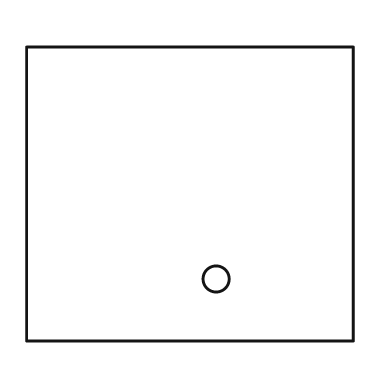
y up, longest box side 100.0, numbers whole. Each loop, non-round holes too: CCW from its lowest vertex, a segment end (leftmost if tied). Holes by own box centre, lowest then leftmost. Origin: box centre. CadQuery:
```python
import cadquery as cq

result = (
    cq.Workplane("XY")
    .moveTo(-50.0, -45.0)
    .lineTo(50.0, -45.0)
    .lineTo(50.0, 45.0)
    .lineTo(-50.0, 45.0)
    .close()
    .moveTo(8.0, -26.0)
    .circle(4.0)
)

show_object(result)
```